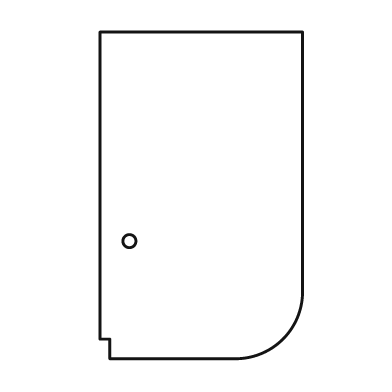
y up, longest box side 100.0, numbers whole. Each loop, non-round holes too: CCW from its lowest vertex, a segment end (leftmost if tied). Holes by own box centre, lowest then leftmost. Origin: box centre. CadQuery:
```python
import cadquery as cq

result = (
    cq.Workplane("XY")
    .moveTo(-28.0, -50.0)
    .lineTo(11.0, -50.0)
    .threePointArc((25.0, -44.0), (31.0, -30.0))
    .lineTo(31.0, 50.0)
    .lineTo(-31.0, 50.0)
    .lineTo(-31.0, -44.0)
    .lineTo(-28.0, -44.0)
    .close()
    .moveTo(-22.0, -14.0)
    .circle(2.0)
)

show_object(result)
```